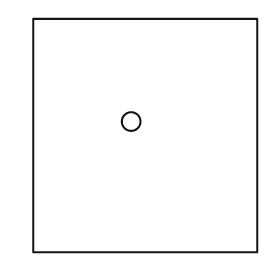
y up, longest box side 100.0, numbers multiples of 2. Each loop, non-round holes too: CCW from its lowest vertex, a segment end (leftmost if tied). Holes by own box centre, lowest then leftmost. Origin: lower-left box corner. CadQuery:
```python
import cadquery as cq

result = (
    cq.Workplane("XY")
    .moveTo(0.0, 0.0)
    .lineTo(96.0, 0.0)
    .lineTo(96.0, 100.0)
    .lineTo(0.0, 100.0)
    .close()
    .moveTo(42.0, 56.0)
    .circle(4.0)
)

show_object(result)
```